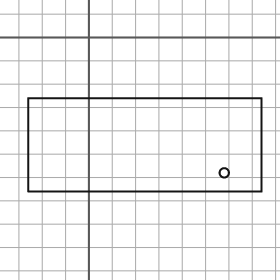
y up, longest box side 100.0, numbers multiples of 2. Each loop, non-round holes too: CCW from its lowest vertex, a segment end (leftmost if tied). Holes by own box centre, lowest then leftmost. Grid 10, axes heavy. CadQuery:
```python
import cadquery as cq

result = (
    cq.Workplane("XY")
    .moveTo(-26.0, -66.0)
    .lineTo(74.0, -66.0)
    .lineTo(74.0, -26.0)
    .lineTo(-26.0, -26.0)
    .close()
    .moveTo(58.0, -58.0)
    .circle(2.0)
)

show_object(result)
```